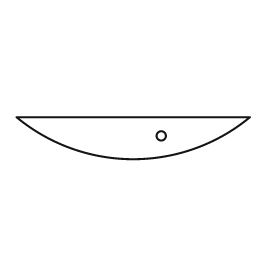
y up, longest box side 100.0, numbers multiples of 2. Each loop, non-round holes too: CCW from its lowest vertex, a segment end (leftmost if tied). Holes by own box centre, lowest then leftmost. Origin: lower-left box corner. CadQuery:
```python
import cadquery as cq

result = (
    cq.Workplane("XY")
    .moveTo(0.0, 18.0)
    .threePointArc((50.0, 0.0), (100.0, 18.0))
    .close()
    .moveTo(62.0, 10.0)
    .circle(2.0)
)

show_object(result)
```